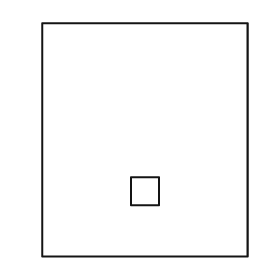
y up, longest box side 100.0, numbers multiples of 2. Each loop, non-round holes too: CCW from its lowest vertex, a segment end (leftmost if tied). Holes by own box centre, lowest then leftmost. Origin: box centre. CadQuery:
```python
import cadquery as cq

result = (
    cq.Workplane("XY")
    .moveTo(-44.0, -50.0)
    .lineTo(44.0, -50.0)
    .lineTo(44.0, 50.0)
    .lineTo(-44.0, 50.0)
    .close()
    .moveTo(-6.0, -28.0)
    .lineTo(6.0, -28.0)
    .lineTo(6.0, -16.0)
    .lineTo(-6.0, -16.0)
    .close()
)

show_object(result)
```